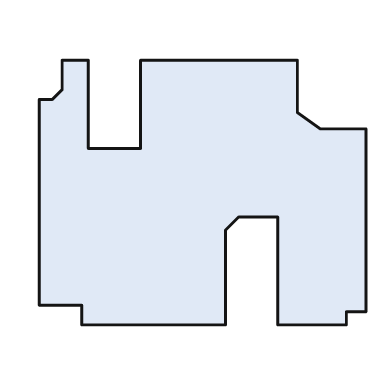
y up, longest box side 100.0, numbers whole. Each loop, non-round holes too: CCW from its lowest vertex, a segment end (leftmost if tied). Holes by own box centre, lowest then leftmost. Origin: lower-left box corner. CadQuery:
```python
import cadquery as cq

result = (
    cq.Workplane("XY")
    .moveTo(13.0, 0.0)
    .lineTo(57.0, 0.0)
    .lineTo(57.0, 29.0)
    .lineTo(61.0, 33.0)
    .lineTo(73.0, 33.0)
    .lineTo(73.0, 0.0)
    .lineTo(94.0, 0.0)
    .lineTo(94.0, 4.0)
    .lineTo(100.0, 4.0)
    .lineTo(100.0, 60.0)
    .lineTo(86.0, 60.0)
    .lineTo(79.0, 65.0)
    .lineTo(79.0, 81.0)
    .lineTo(31.0, 81.0)
    .lineTo(31.0, 54.0)
    .lineTo(15.0, 54.0)
    .lineTo(15.0, 81.0)
    .lineTo(7.0, 81.0)
    .lineTo(7.0, 72.0)
    .lineTo(4.0, 69.0)
    .lineTo(0.0, 69.0)
    .lineTo(0.0, 6.0)
    .lineTo(13.0, 6.0)
    .close()
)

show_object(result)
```